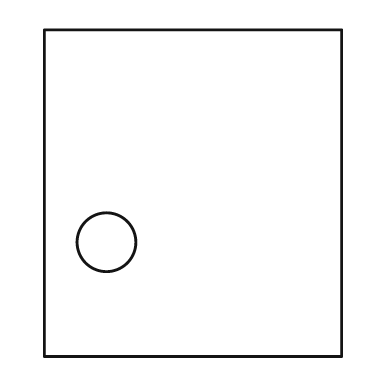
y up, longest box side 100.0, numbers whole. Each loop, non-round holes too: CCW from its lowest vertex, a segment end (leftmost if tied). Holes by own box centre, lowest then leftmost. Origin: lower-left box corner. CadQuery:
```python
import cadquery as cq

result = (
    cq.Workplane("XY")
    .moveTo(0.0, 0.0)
    .lineTo(91.0, 0.0)
    .lineTo(91.0, 100.0)
    .lineTo(0.0, 100.0)
    .close()
    .moveTo(19.0, 35.0)
    .circle(9.0)
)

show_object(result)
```